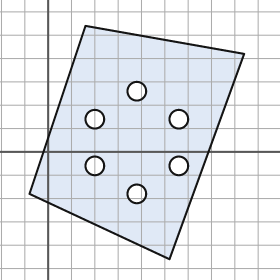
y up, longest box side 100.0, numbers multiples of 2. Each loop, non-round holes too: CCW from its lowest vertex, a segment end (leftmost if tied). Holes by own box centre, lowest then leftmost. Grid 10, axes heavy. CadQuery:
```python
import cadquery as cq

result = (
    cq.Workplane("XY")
    .moveTo(52.0, -46.0)
    .lineTo(84.0, 42.0)
    .lineTo(16.0, 54.0)
    .lineTo(-8.0, -18.0)
    .close()
    .moveTo(38.0, -18.0)
    .circle(4.0)
    .moveTo(20.0, -6.0)
    .circle(4.0)
    .moveTo(56.0, -6.0)
    .circle(4.0)
    .moveTo(20.0, 14.0)
    .circle(4.0)
    .moveTo(56.0, 14.0)
    .circle(4.0)
    .moveTo(38.0, 26.0)
    .circle(4.0)
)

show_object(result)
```